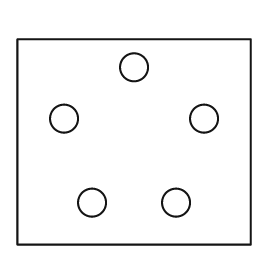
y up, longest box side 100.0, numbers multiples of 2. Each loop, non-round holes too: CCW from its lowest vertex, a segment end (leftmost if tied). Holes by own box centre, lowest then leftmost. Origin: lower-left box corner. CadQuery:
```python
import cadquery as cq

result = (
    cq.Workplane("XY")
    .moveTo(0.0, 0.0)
    .lineTo(100.0, 0.0)
    .lineTo(100.0, 88.0)
    .lineTo(0.0, 88.0)
    .close()
    .moveTo(32.0, 18.0)
    .circle(6.0)
    .moveTo(68.0, 18.0)
    .circle(6.0)
    .moveTo(20.0, 54.0)
    .circle(6.0)
    .moveTo(80.0, 54.0)
    .circle(6.0)
    .moveTo(50.0, 76.0)
    .circle(6.0)
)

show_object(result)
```